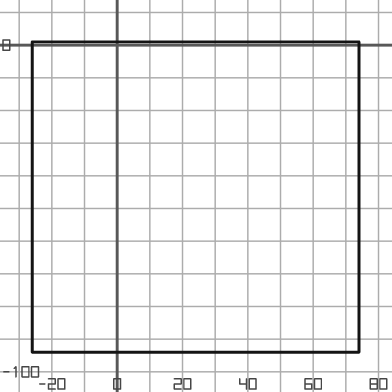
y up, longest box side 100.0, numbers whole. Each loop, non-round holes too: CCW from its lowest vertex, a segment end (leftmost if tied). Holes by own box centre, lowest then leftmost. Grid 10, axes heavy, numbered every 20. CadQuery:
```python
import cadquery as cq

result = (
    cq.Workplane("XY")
    .moveTo(-26.0, -94.0)
    .lineTo(74.0, -94.0)
    .lineTo(74.0, 1.0)
    .lineTo(-26.0, 1.0)
    .close()
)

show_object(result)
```